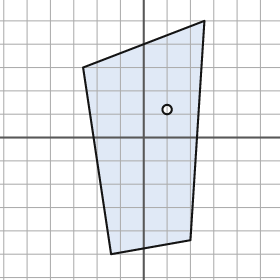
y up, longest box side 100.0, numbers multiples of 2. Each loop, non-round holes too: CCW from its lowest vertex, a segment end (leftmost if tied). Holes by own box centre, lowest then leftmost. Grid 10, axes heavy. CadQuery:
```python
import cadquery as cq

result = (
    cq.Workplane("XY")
    .moveTo(-14.0, -50.0)
    .lineTo(20.0, -44.0)
    .lineTo(26.0, 50.0)
    .lineTo(-26.0, 30.0)
    .close()
    .moveTo(10.0, 12.0)
    .circle(2.0)
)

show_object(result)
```